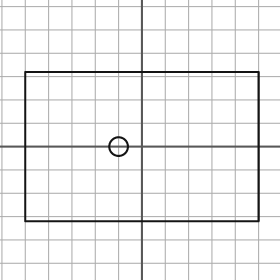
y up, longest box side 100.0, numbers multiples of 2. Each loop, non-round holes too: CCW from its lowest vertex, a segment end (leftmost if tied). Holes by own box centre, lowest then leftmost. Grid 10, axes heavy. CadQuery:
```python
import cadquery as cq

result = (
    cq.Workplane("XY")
    .moveTo(-50.0, -32.0)
    .lineTo(50.0, -32.0)
    .lineTo(50.0, 32.0)
    .lineTo(-50.0, 32.0)
    .close()
    .moveTo(-10.0, 0.0)
    .circle(4.0)
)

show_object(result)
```